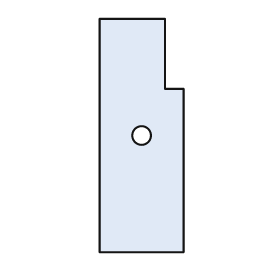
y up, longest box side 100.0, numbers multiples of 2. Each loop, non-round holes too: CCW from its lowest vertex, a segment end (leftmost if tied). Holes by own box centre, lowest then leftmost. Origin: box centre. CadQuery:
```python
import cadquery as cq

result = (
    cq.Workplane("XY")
    .moveTo(-18.0, -50.0)
    .lineTo(18.0, -50.0)
    .lineTo(18.0, 20.0)
    .lineTo(10.0, 20.0)
    .lineTo(10.0, 50.0)
    .lineTo(-18.0, 50.0)
    .close()
    .moveTo(0.0, 0.0)
    .circle(4.0)
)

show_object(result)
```